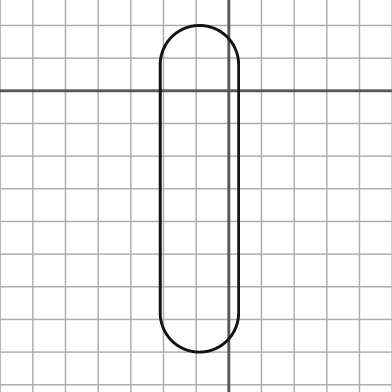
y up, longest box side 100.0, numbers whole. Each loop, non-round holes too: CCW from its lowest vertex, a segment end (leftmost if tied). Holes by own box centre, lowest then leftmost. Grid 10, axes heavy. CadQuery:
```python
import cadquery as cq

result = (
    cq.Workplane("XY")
    .moveTo(-21.0, -68.0)
    .threePointArc((-9.0, -80.0), (3.0, -68.0))
    .lineTo(3.0, 8.0)
    .threePointArc((-9.0, 20.0), (-21.0, 8.0))
    .close()
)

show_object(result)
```